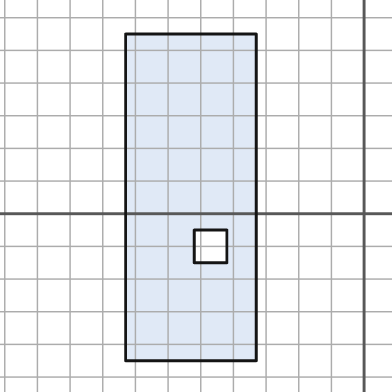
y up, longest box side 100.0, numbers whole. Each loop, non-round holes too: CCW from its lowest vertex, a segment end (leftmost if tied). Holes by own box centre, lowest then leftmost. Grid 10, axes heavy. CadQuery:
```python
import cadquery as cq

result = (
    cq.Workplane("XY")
    .moveTo(-73.0, -45.0)
    .lineTo(-33.0, -45.0)
    .lineTo(-33.0, 55.0)
    .lineTo(-73.0, 55.0)
    .close()
    .moveTo(-52.0, -15.0)
    .lineTo(-42.0, -15.0)
    .lineTo(-42.0, -5.0)
    .lineTo(-52.0, -5.0)
    .close()
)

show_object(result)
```